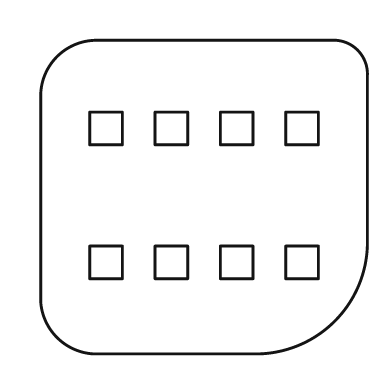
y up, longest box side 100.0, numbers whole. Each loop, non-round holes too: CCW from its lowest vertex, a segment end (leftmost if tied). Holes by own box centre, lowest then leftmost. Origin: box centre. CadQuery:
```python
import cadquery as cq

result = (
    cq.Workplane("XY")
    .moveTo(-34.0, -48.0)
    .lineTo(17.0, -48.0)
    .threePointArc((40.0, -38.0), (50.0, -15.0))
    .lineTo(50.0, 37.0)
    .threePointArc((47.0, 45.0), (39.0, 48.0))
    .lineTo(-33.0, 48.0)
    .threePointArc((-45.0, 43.0), (-50.0, 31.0))
    .lineTo(-50.0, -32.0)
    .threePointArc((-45.0, -43.0), (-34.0, -48.0))
    .close()
    .moveTo(-35.0, -25.0)
    .lineTo(-25.0, -25.0)
    .lineTo(-25.0, -15.0)
    .lineTo(-35.0, -15.0)
    .close()
    .moveTo(-15.0, -25.0)
    .lineTo(-5.0, -25.0)
    .lineTo(-5.0, -15.0)
    .lineTo(-15.0, -15.0)
    .close()
    .moveTo(5.0, -25.0)
    .lineTo(15.0, -25.0)
    .lineTo(15.0, -15.0)
    .lineTo(5.0, -15.0)
    .close()
    .moveTo(25.0, -25.0)
    .lineTo(35.0, -25.0)
    .lineTo(35.0, -15.0)
    .lineTo(25.0, -15.0)
    .close()
    .moveTo(-35.0, 16.0)
    .lineTo(-25.0, 16.0)
    .lineTo(-25.0, 26.0)
    .lineTo(-35.0, 26.0)
    .close()
    .moveTo(-15.0, 16.0)
    .lineTo(-5.0, 16.0)
    .lineTo(-5.0, 26.0)
    .lineTo(-15.0, 26.0)
    .close()
    .moveTo(5.0, 16.0)
    .lineTo(15.0, 16.0)
    .lineTo(15.0, 26.0)
    .lineTo(5.0, 26.0)
    .close()
    .moveTo(25.0, 16.0)
    .lineTo(35.0, 16.0)
    .lineTo(35.0, 26.0)
    .lineTo(25.0, 26.0)
    .close()
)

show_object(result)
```